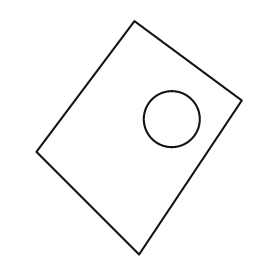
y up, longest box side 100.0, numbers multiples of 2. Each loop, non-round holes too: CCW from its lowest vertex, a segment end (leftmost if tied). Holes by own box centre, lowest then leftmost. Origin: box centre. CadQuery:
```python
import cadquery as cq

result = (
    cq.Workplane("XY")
    .moveTo(0.0, -50.0)
    .lineTo(44.0, 16.0)
    .lineTo(-2.0, 50.0)
    .lineTo(-44.0, -6.0)
    .close()
    .moveTo(14.0, 8.0)
    .circle(12.0)
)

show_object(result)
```